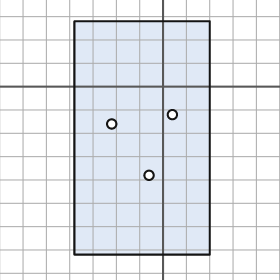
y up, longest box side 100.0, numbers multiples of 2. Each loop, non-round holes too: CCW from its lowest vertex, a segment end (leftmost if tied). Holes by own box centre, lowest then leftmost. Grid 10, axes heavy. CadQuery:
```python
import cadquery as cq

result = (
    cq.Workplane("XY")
    .moveTo(-38.0, -72.0)
    .lineTo(20.0, -72.0)
    .lineTo(20.0, 28.0)
    .lineTo(-38.0, 28.0)
    .close()
    .moveTo(-6.0, -38.0)
    .circle(2.0)
    .moveTo(-22.0, -16.0)
    .circle(2.0)
    .moveTo(4.0, -12.0)
    .circle(2.0)
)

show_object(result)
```